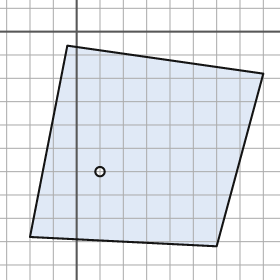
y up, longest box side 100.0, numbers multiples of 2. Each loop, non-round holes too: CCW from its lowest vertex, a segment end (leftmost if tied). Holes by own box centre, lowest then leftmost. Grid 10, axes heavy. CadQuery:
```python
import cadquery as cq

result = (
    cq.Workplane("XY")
    .moveTo(60.0, -92.0)
    .lineTo(80.0, -18.0)
    .lineTo(-4.0, -6.0)
    .lineTo(-20.0, -88.0)
    .close()
    .moveTo(10.0, -60.0)
    .circle(2.0)
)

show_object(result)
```